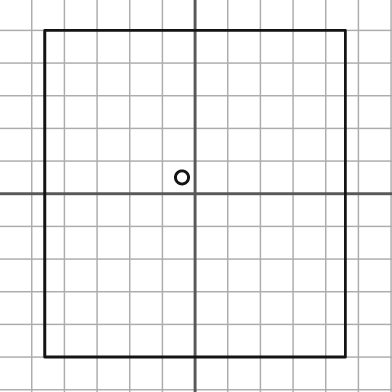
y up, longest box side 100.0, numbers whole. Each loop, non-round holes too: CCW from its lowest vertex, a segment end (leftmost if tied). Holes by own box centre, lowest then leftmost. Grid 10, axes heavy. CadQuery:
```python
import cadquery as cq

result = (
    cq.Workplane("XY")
    .moveTo(-46.0, -50.0)
    .lineTo(46.0, -50.0)
    .lineTo(46.0, 50.0)
    .lineTo(-46.0, 50.0)
    .close()
    .moveTo(-4.0, 5.0)
    .circle(2.0)
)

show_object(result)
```